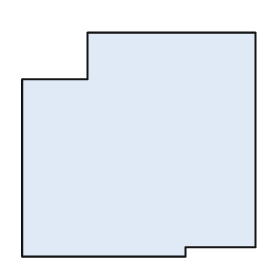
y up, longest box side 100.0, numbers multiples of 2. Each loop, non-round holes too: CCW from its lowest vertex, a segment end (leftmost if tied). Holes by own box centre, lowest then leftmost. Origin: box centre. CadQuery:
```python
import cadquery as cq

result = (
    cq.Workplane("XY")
    .moveTo(-50.0, -48.0)
    .lineTo(20.0, -48.0)
    .lineTo(20.0, -44.0)
    .lineTo(50.0, -44.0)
    .lineTo(50.0, 48.0)
    .lineTo(-22.0, 48.0)
    .lineTo(-22.0, 28.0)
    .lineTo(-50.0, 28.0)
    .close()
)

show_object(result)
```